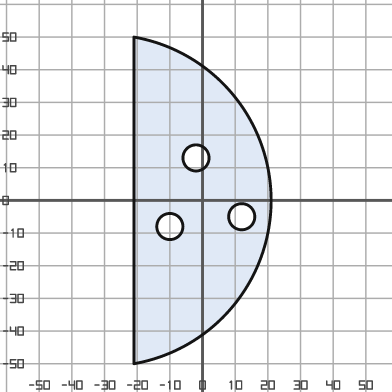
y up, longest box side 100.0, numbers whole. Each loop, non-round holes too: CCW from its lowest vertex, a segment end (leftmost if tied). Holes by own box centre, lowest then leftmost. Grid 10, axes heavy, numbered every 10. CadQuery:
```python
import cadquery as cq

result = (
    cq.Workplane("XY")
    .moveTo(-21.0, -50.0)
    .threePointArc((21.0, 0.0), (-21.0, 50.0))
    .close()
    .moveTo(-10.0, -8.0)
    .circle(4.0)
    .moveTo(12.0, -5.0)
    .circle(4.0)
    .moveTo(-2.0, 13.0)
    .circle(4.0)
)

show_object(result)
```